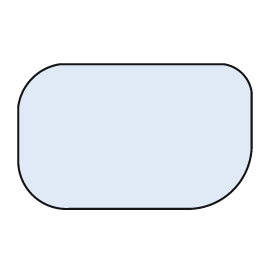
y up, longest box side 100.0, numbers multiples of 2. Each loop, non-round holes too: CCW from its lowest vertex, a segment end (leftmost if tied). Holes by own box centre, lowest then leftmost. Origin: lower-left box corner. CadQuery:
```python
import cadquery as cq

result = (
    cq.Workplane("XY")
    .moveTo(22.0, 0.0)
    .lineTo(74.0, 0.0)
    .threePointArc((92.0, 8.0), (100.0, 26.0))
    .lineTo(100.0, 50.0)
    .threePointArc((96.0, 58.0), (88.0, 62.0))
    .lineTo(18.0, 62.0)
    .threePointArc((6.0, 56.0), (0.0, 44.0))
    .lineTo(0.0, 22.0)
    .threePointArc((6.0, 6.0), (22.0, 0.0))
    .close()
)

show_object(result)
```